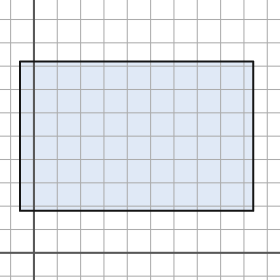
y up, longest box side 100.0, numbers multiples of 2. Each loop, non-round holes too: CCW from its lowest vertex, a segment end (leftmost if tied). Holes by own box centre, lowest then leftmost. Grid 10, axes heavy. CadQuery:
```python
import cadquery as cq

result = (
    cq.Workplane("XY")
    .moveTo(-6.0, 18.0)
    .lineTo(94.0, 18.0)
    .lineTo(94.0, 82.0)
    .lineTo(-6.0, 82.0)
    .close()
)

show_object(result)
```